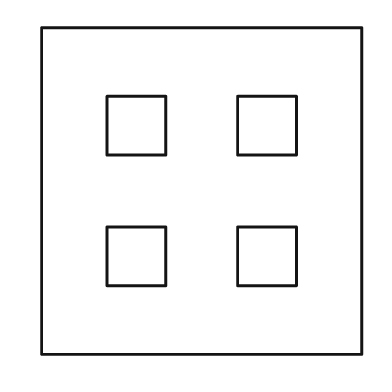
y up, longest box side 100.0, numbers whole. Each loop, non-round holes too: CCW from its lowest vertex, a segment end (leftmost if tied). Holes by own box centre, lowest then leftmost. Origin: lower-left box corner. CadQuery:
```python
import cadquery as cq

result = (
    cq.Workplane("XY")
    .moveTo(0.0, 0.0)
    .lineTo(98.0, 0.0)
    .lineTo(98.0, 100.0)
    .lineTo(0.0, 100.0)
    .close()
    .moveTo(20.0, 21.0)
    .lineTo(38.0, 21.0)
    .lineTo(38.0, 39.0)
    .lineTo(20.0, 39.0)
    .close()
    .moveTo(60.0, 21.0)
    .lineTo(78.0, 21.0)
    .lineTo(78.0, 39.0)
    .lineTo(60.0, 39.0)
    .close()
    .moveTo(20.0, 61.0)
    .lineTo(38.0, 61.0)
    .lineTo(38.0, 79.0)
    .lineTo(20.0, 79.0)
    .close()
    .moveTo(60.0, 61.0)
    .lineTo(78.0, 61.0)
    .lineTo(78.0, 79.0)
    .lineTo(60.0, 79.0)
    .close()
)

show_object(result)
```